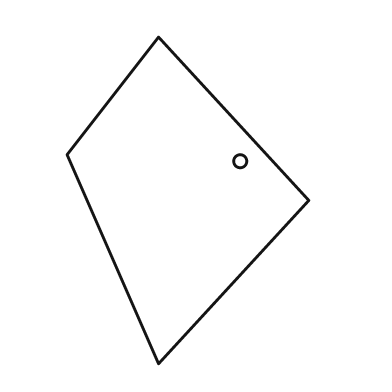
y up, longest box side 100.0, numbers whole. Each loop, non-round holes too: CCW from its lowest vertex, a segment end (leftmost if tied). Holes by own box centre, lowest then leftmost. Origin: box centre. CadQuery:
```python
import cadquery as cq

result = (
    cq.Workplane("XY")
    .moveTo(-9.0, -50.0)
    .lineTo(37.0, 0.0)
    .lineTo(-9.0, 50.0)
    .lineTo(-37.0, 14.0)
    .close()
    .moveTo(16.0, 12.0)
    .circle(2.0)
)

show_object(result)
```